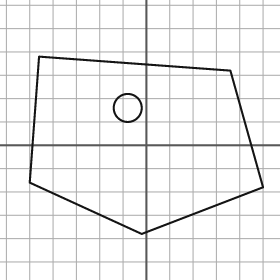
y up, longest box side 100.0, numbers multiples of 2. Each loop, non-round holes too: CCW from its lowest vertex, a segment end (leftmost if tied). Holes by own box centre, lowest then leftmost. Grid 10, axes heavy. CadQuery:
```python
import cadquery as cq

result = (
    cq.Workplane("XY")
    .moveTo(-2.0, -38.0)
    .lineTo(50.0, -18.0)
    .lineTo(36.0, 32.0)
    .lineTo(-46.0, 38.0)
    .lineTo(-50.0, -16.0)
    .close()
    .moveTo(-8.0, 16.0)
    .circle(6.0)
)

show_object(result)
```